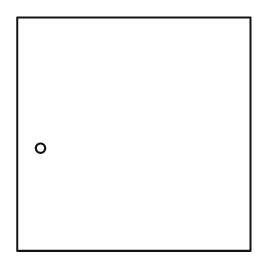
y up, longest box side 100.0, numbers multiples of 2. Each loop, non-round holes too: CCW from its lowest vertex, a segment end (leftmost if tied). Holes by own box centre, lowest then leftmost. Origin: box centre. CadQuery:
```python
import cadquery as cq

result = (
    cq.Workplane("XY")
    .moveTo(-50.0, -50.0)
    .lineTo(50.0, -50.0)
    .lineTo(50.0, 50.0)
    .lineTo(-50.0, 50.0)
    .close()
    .moveTo(-40.0, -6.0)
    .circle(2.0)
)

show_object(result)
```